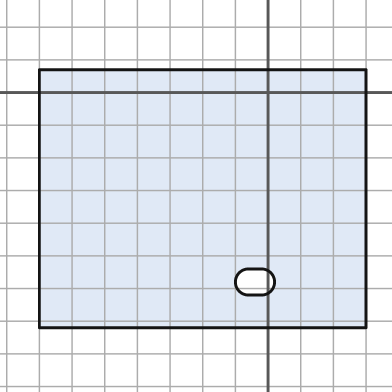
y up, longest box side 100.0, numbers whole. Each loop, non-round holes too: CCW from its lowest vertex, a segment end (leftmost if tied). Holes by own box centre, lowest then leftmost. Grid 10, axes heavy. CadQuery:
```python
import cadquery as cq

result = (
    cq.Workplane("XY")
    .moveTo(-70.0, -72.0)
    .lineTo(30.0, -72.0)
    .lineTo(30.0, 7.0)
    .lineTo(-70.0, 7.0)
    .close()
    .moveTo(-6.0, -62.0)
    .lineTo(-2.0, -62.0)
    .threePointArc((2.0, -58.0), (-2.0, -54.0))
    .lineTo(-6.0, -54.0)
    .threePointArc((-10.0, -58.0), (-6.0, -62.0))
    .close()
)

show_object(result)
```